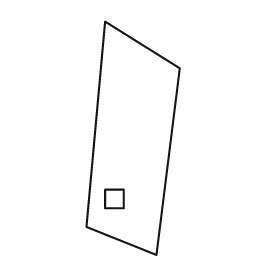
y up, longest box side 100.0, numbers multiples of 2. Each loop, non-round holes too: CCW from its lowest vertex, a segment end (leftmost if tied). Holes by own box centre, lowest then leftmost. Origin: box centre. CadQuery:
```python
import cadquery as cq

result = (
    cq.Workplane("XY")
    .moveTo(10.0, -50.0)
    .lineTo(20.0, 30.0)
    .lineTo(-12.0, 50.0)
    .lineTo(-20.0, -38.0)
    .close()
    .moveTo(-12.0, -30.0)
    .lineTo(-4.0, -30.0)
    .lineTo(-4.0, -22.0)
    .lineTo(-12.0, -22.0)
    .close()
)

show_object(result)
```